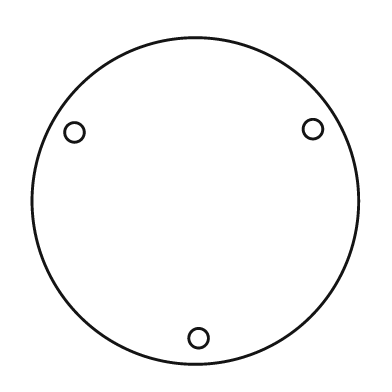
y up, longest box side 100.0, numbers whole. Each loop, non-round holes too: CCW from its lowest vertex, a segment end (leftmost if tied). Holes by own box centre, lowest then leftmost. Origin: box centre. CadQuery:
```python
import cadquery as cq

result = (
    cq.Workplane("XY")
    .moveTo(0.0, 0.0)
    .circle(50.0)
    .moveTo(1.0, -42.0)
    .circle(3.0)
    .moveTo(-37.0, 21.0)
    .circle(3.0)
    .moveTo(36.0, 22.0)
    .circle(3.0)
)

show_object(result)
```